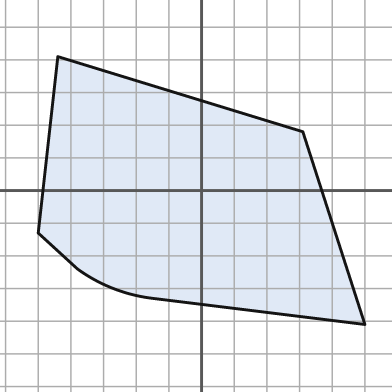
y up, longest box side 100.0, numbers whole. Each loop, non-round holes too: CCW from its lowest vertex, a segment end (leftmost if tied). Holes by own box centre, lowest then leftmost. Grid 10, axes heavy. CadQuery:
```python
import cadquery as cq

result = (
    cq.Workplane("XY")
    .moveTo(50.0, -41.0)
    .lineTo(31.0, 18.0)
    .lineTo(-44.0, 41.0)
    .lineTo(-50.0, -13.0)
    .lineTo(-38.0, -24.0)
    .threePointArc((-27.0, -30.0), (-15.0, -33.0))
    .close()
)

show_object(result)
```